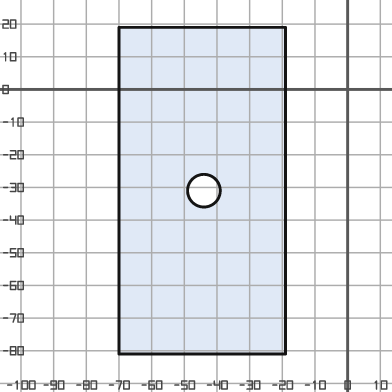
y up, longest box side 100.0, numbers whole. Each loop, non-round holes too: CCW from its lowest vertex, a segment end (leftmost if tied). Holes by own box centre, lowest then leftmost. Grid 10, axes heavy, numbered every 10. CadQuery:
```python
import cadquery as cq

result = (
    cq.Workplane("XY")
    .moveTo(-70.0, -81.0)
    .lineTo(-19.0, -81.0)
    .lineTo(-19.0, 19.0)
    .lineTo(-70.0, 19.0)
    .close()
    .moveTo(-44.0, -31.0)
    .circle(5.0)
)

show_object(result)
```